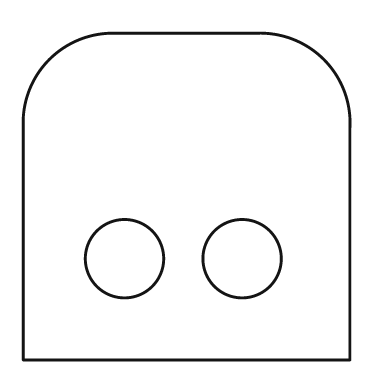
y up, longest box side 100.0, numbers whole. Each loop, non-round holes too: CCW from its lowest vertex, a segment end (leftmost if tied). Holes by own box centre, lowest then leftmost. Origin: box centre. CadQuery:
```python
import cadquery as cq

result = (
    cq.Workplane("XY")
    .moveTo(-50.0, -50.0)
    .lineTo(50.0, -50.0)
    .lineTo(50.0, 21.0)
    .threePointArc((42.0, 42.0), (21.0, 50.0))
    .lineTo(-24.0, 50.0)
    .threePointArc((-42.0, 42.0), (-50.0, 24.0))
    .close()
    .moveTo(-19.0, -19.0)
    .circle(12.0)
    .moveTo(17.0, -19.0)
    .circle(12.0)
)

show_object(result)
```